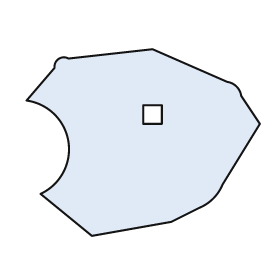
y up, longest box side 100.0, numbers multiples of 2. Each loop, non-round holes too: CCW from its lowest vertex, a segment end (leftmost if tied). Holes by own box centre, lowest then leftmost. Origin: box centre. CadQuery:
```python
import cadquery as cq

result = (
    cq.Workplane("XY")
    .moveTo(-22.0, -40.0)
    .lineTo(12.0, -34.0)
    .lineTo(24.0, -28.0)
    .threePointArc((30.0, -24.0), (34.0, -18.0))
    .lineTo(50.0, 8.0)
    .lineTo(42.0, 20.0)
    .threePointArc((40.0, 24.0), (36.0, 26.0))
    .lineTo(4.0, 40.0)
    .lineTo(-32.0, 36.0)
    .threePointArc((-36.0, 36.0), (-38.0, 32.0))
    .lineTo(-50.0, 18.0)
    .threePointArc((-32.0, 0.0), (-44.0, -22.0))
    .close()
    .moveTo(0.0, 8.0)
    .lineTo(8.0, 8.0)
    .lineTo(8.0, 16.0)
    .lineTo(0.0, 16.0)
    .close()
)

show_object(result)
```